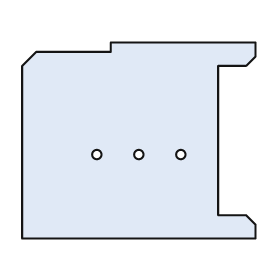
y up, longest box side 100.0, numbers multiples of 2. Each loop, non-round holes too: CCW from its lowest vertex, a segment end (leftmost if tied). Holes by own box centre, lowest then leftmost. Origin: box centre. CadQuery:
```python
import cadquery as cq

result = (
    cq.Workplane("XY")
    .moveTo(-50.0, -42.0)
    .lineTo(50.0, -42.0)
    .lineTo(50.0, -36.0)
    .lineTo(46.0, -32.0)
    .lineTo(34.0, -32.0)
    .lineTo(34.0, 32.0)
    .lineTo(46.0, 32.0)
    .lineTo(50.0, 36.0)
    .lineTo(50.0, 42.0)
    .lineTo(-12.0, 42.0)
    .lineTo(-12.0, 38.0)
    .lineTo(-44.0, 38.0)
    .lineTo(-50.0, 32.0)
    .close()
    .moveTo(-18.0, -6.0)
    .circle(2.0)
    .moveTo(0.0, -6.0)
    .circle(2.0)
    .moveTo(18.0, -6.0)
    .circle(2.0)
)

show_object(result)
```